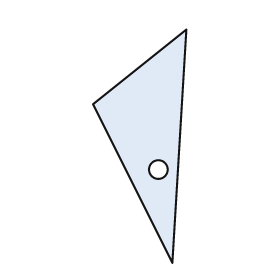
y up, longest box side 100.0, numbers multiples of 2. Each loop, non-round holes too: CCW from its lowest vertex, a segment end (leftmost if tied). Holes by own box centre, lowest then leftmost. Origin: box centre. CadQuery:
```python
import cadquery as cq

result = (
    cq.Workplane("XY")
    .moveTo(14.0, -50.0)
    .lineTo(20.0, 50.0)
    .lineTo(-20.0, 18.0)
    .close()
    .moveTo(8.0, -10.0)
    .circle(4.0)
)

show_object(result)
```